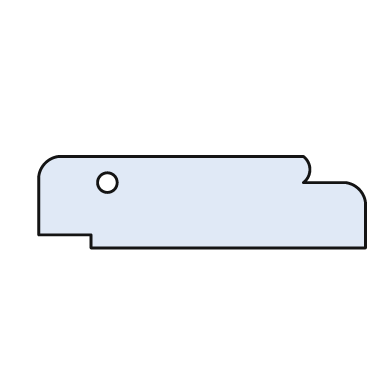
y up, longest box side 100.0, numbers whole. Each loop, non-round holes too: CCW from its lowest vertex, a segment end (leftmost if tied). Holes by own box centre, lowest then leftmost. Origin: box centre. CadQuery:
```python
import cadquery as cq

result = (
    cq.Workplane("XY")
    .moveTo(-34.0, -14.0)
    .lineTo(50.0, -14.0)
    .lineTo(50.0, 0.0)
    .threePointArc((48.0, 4.0), (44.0, 6.0))
    .lineTo(31.0, 6.0)
    .threePointArc((33.0, 10.0), (31.0, 14.0))
    .lineTo(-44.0, 14.0)
    .threePointArc((-48.0, 12.0), (-50.0, 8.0))
    .lineTo(-50.0, -10.0)
    .lineTo(-34.0, -10.0)
    .close()
    .moveTo(-29.0, 6.0)
    .circle(3.0)
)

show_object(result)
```